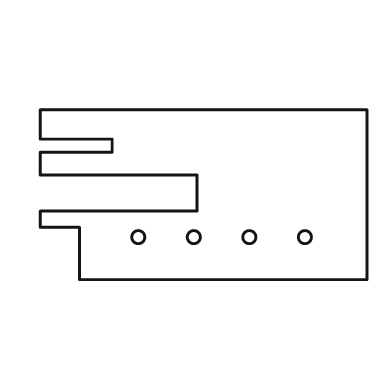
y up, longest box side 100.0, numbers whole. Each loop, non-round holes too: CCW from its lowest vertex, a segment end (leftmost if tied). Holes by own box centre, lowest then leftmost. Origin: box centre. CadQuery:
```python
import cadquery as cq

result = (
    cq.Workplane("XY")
    .moveTo(-38.0, -26.0)
    .lineTo(50.0, -26.0)
    .lineTo(50.0, 26.0)
    .lineTo(-50.0, 26.0)
    .lineTo(-50.0, 17.0)
    .lineTo(-28.0, 17.0)
    .lineTo(-28.0, 13.0)
    .lineTo(-50.0, 13.0)
    .lineTo(-50.0, 6.0)
    .lineTo(-2.0, 6.0)
    .lineTo(-2.0, -5.0)
    .lineTo(-50.0, -5.0)
    .lineTo(-50.0, -10.0)
    .lineTo(-38.0, -10.0)
    .close()
    .moveTo(-20.0, -13.0)
    .circle(2.0)
    .moveTo(-3.0, -13.0)
    .circle(2.0)
    .moveTo(14.0, -13.0)
    .circle(2.0)
    .moveTo(31.0, -13.0)
    .circle(2.0)
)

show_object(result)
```